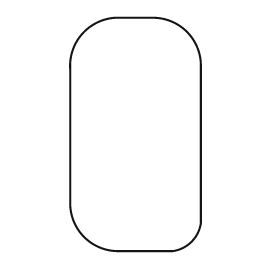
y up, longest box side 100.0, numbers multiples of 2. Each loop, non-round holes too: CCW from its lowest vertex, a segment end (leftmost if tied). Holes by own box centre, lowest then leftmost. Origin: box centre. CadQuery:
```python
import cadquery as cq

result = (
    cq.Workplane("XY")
    .moveTo(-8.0, -50.0)
    .lineTo(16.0, -50.0)
    .threePointArc((24.0, -46.0), (28.0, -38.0))
    .lineTo(28.0, 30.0)
    .threePointArc((22.0, 44.0), (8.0, 50.0))
    .lineTo(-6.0, 50.0)
    .threePointArc((-22.0, 44.0), (-28.0, 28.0))
    .lineTo(-28.0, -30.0)
    .threePointArc((-22.0, -44.0), (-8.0, -50.0))
    .close()
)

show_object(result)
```